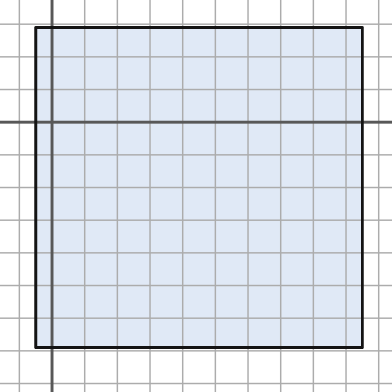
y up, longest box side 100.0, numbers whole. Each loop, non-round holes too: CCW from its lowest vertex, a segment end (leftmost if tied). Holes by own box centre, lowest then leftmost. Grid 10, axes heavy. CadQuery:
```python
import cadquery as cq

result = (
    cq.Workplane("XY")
    .moveTo(-5.0, -69.0)
    .lineTo(95.0, -69.0)
    .lineTo(95.0, 29.0)
    .lineTo(-5.0, 29.0)
    .close()
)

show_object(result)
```